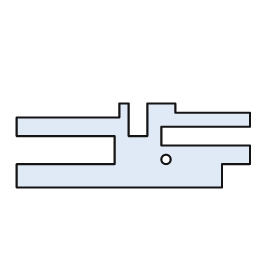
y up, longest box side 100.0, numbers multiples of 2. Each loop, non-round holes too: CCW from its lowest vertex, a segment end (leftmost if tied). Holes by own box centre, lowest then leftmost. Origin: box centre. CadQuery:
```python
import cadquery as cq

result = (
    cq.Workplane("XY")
    .moveTo(-50.0, -18.0)
    .lineTo(38.0, -18.0)
    .lineTo(38.0, -8.0)
    .lineTo(50.0, -8.0)
    .lineTo(50.0, 0.0)
    .lineTo(12.0, 0.0)
    .lineTo(12.0, 8.0)
    .lineTo(50.0, 8.0)
    .lineTo(50.0, 14.0)
    .lineTo(18.0, 14.0)
    .lineTo(18.0, 18.0)
    .lineTo(6.0, 18.0)
    .lineTo(6.0, 4.0)
    .lineTo(-2.0, 4.0)
    .lineTo(-2.0, 18.0)
    .lineTo(-6.0, 18.0)
    .lineTo(-6.0, 12.0)
    .lineTo(-50.0, 12.0)
    .lineTo(-50.0, 4.0)
    .lineTo(-8.0, 4.0)
    .lineTo(-8.0, -8.0)
    .lineTo(-50.0, -8.0)
    .close()
    .moveTo(14.0, -6.0)
    .circle(2.0)
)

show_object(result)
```